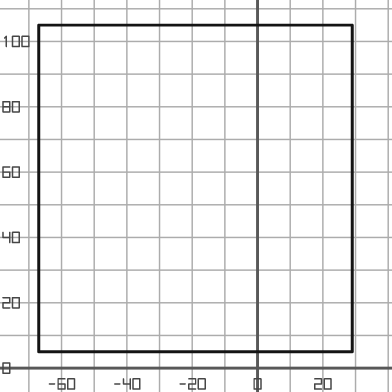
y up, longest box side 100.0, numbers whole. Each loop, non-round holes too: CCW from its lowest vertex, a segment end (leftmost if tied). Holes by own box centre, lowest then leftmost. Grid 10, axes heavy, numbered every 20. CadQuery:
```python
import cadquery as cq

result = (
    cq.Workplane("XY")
    .moveTo(-67.0, 5.0)
    .lineTo(29.0, 5.0)
    .lineTo(29.0, 105.0)
    .lineTo(-67.0, 105.0)
    .close()
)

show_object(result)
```